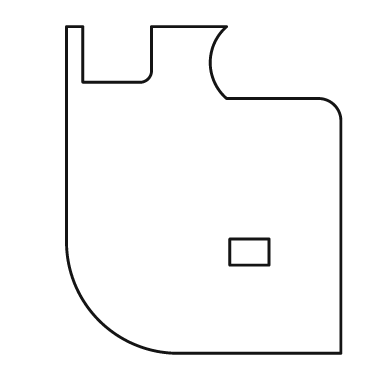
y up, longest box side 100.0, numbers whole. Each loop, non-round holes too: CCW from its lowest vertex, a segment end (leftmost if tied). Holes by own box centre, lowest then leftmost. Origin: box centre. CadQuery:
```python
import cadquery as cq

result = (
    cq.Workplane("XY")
    .moveTo(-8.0, -50.0)
    .lineTo(42.0, -50.0)
    .lineTo(42.0, 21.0)
    .threePointArc((40.0, 26.0), (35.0, 28.0))
    .lineTo(7.0, 28.0)
    .threePointArc((2.0, 39.0), (7.0, 50.0))
    .lineTo(-16.0, 50.0)
    .lineTo(-16.0, 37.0)
    .threePointArc((-17.0, 34.0), (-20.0, 33.0))
    .lineTo(-37.0, 33.0)
    .lineTo(-37.0, 50.0)
    .lineTo(-42.0, 50.0)
    .lineTo(-42.0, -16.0)
    .threePointArc((-32.0, -40.0), (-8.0, -50.0))
    .close()
    .moveTo(8.0, -23.0)
    .lineTo(20.0, -23.0)
    .lineTo(20.0, -15.0)
    .lineTo(8.0, -15.0)
    .close()
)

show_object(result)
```